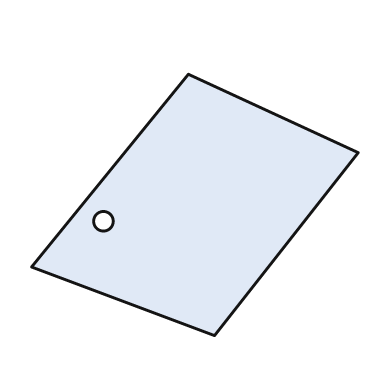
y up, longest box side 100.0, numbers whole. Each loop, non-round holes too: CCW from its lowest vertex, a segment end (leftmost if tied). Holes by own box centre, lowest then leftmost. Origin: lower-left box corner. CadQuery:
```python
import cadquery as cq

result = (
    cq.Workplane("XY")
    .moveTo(56.0, 0.0)
    .lineTo(100.0, 56.0)
    .lineTo(48.0, 80.0)
    .lineTo(0.0, 21.0)
    .close()
    .moveTo(22.0, 35.0)
    .circle(3.0)
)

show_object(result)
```